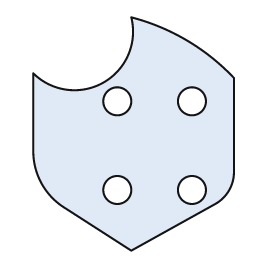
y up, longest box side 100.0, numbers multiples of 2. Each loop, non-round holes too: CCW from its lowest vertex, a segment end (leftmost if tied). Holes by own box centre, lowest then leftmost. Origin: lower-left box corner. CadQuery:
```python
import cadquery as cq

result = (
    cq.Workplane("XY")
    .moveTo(42.0, 0.0)
    .lineTo(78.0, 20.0)
    .threePointArc((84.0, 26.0), (86.0, 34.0))
    .lineTo(86.0, 74.0)
    .threePointArc((66.0, 90.0), (42.0, 100.0))
    .threePointArc((30.0, 72.0), (0.0, 76.0))
    .lineTo(0.0, 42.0)
    .threePointArc((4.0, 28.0), (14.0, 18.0))
    .close()
    .moveTo(36.0, 26.0)
    .circle(6.0)
    .moveTo(68.0, 26.0)
    .circle(6.0)
    .moveTo(36.0, 64.0)
    .circle(6.0)
    .moveTo(68.0, 64.0)
    .circle(6.0)
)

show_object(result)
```